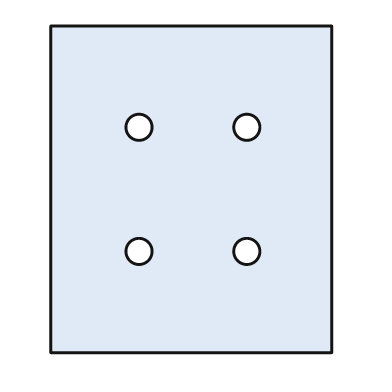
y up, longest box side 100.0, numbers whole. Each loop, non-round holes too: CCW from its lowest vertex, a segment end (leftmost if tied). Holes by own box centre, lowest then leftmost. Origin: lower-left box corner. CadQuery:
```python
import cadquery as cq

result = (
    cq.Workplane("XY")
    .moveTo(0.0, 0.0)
    .lineTo(86.0, 0.0)
    .lineTo(86.0, 100.0)
    .lineTo(0.0, 100.0)
    .close()
    .moveTo(27.0, 31.0)
    .circle(4.0)
    .moveTo(60.0, 31.0)
    .circle(4.0)
    .moveTo(27.0, 69.0)
    .circle(4.0)
    .moveTo(60.0, 69.0)
    .circle(4.0)
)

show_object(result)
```